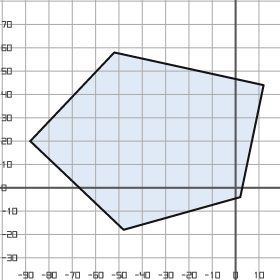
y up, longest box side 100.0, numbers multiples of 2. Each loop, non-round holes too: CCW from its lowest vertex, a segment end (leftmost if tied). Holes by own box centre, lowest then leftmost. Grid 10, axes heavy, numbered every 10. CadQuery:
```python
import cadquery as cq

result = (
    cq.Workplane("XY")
    .moveTo(-48.0, -18.0)
    .lineTo(2.0, -4.0)
    .lineTo(12.0, 44.0)
    .lineTo(-52.0, 58.0)
    .lineTo(-88.0, 20.0)
    .close()
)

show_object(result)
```